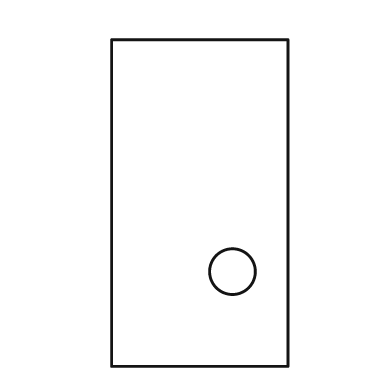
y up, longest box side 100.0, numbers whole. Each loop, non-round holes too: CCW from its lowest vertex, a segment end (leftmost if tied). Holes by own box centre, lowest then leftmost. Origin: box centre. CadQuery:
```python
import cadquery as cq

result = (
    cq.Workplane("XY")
    .moveTo(-27.0, -50.0)
    .lineTo(27.0, -50.0)
    .lineTo(27.0, 50.0)
    .lineTo(-27.0, 50.0)
    .close()
    .moveTo(10.0, -21.0)
    .circle(7.0)
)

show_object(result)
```